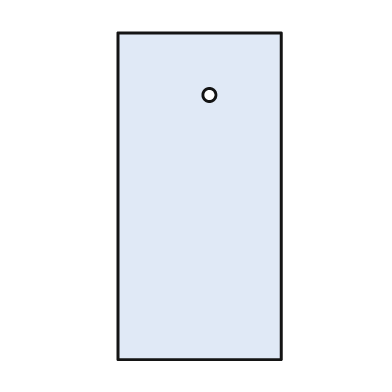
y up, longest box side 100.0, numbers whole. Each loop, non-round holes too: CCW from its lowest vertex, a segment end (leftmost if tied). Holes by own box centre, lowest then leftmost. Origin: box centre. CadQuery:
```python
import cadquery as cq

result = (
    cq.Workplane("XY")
    .moveTo(-25.0, -50.0)
    .lineTo(25.0, -50.0)
    .lineTo(25.0, 50.0)
    .lineTo(-25.0, 50.0)
    .close()
    .moveTo(3.0, 31.0)
    .circle(2.0)
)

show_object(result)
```